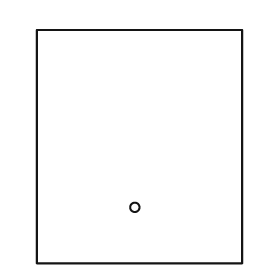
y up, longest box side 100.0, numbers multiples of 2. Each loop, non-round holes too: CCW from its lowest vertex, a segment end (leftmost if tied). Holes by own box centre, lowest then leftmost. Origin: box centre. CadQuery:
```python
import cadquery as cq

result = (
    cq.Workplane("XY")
    .moveTo(-44.0, -50.0)
    .lineTo(44.0, -50.0)
    .lineTo(44.0, 50.0)
    .lineTo(-44.0, 50.0)
    .close()
    .moveTo(-2.0, -26.0)
    .circle(2.0)
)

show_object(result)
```